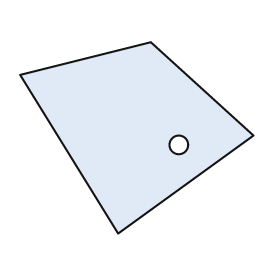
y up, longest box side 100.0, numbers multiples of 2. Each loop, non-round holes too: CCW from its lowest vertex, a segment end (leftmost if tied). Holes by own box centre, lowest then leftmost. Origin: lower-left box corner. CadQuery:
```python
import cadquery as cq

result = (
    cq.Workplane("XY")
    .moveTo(42.0, 0.0)
    .lineTo(100.0, 42.0)
    .lineTo(56.0, 82.0)
    .lineTo(0.0, 68.0)
    .close()
    .moveTo(68.0, 38.0)
    .circle(4.0)
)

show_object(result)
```